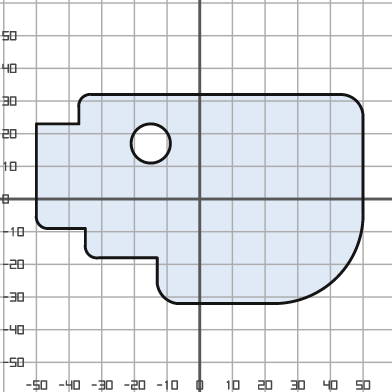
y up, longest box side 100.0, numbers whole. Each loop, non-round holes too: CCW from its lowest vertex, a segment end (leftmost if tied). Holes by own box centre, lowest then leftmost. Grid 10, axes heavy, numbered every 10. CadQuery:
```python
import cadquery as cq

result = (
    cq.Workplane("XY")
    .moveTo(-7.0, -32.0)
    .lineTo(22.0, -32.0)
    .threePointArc((42.0, -24.0), (50.0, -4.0))
    .lineTo(50.0, 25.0)
    .threePointArc((48.0, 30.0), (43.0, 32.0))
    .lineTo(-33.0, 32.0)
    .threePointArc((-36.0, 31.0), (-37.0, 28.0))
    .lineTo(-37.0, 23.0)
    .lineTo(-50.0, 23.0)
    .lineTo(-50.0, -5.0)
    .threePointArc((-49.0, -8.0), (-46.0, -9.0))
    .lineTo(-35.0, -9.0)
    .lineTo(-35.0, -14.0)
    .threePointArc((-34.0, -17.0), (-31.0, -18.0))
    .lineTo(-13.0, -18.0)
    .lineTo(-13.0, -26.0)
    .threePointArc((-11.0, -30.0), (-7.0, -32.0))
    .close()
    .moveTo(-15.0, 17.0)
    .circle(6.0)
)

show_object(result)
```